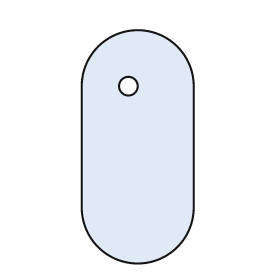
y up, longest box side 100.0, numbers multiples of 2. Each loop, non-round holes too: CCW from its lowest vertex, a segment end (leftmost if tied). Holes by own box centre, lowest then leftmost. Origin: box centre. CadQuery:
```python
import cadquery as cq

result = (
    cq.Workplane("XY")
    .moveTo(-24.0, -26.0)
    .threePointArc((0.0, -50.0), (24.0, -26.0))
    .lineTo(24.0, 26.0)
    .threePointArc((0.0, 50.0), (-24.0, 26.0))
    .close()
    .moveTo(-4.0, 26.0)
    .circle(4.0)
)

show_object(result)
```